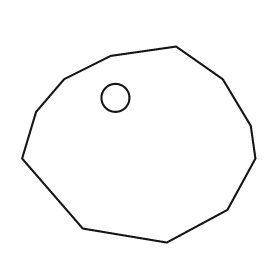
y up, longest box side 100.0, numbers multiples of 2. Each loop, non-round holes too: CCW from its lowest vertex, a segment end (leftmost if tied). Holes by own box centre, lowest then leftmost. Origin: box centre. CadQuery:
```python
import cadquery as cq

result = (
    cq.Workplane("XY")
    .moveTo(12.0, -42.0)
    .lineTo(38.0, -28.0)
    .lineTo(50.0, -6.0)
    .lineTo(48.0, 8.0)
    .lineTo(36.0, 28.0)
    .lineTo(16.0, 42.0)
    .lineTo(-12.0, 38.0)
    .lineTo(-32.0, 28.0)
    .lineTo(-44.0, 14.0)
    .lineTo(-50.0, -6.0)
    .lineTo(-24.0, -36.0)
    .close()
    .moveTo(-10.0, 20.0)
    .circle(6.0)
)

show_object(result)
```